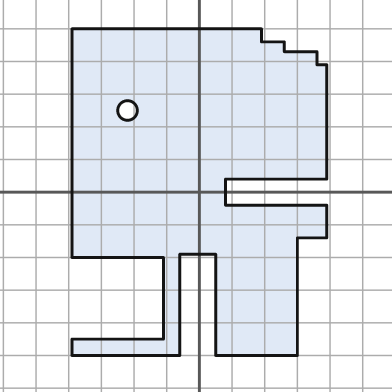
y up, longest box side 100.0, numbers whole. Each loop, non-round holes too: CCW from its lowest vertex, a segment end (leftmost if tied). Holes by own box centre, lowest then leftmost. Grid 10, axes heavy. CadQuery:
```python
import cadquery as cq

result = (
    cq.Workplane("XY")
    .moveTo(-39.0, -50.0)
    .lineTo(-6.0, -50.0)
    .lineTo(-6.0, -19.0)
    .lineTo(5.0, -19.0)
    .lineTo(5.0, -50.0)
    .lineTo(30.0, -50.0)
    .lineTo(30.0, -14.0)
    .lineTo(39.0, -14.0)
    .lineTo(39.0, -4.0)
    .lineTo(8.0, -4.0)
    .lineTo(8.0, 4.0)
    .lineTo(39.0, 4.0)
    .lineTo(39.0, 39.0)
    .lineTo(36.0, 39.0)
    .lineTo(36.0, 43.0)
    .lineTo(26.0, 43.0)
    .lineTo(26.0, 46.0)
    .lineTo(19.0, 46.0)
    .lineTo(19.0, 50.0)
    .lineTo(-39.0, 50.0)
    .lineTo(-39.0, -20.0)
    .lineTo(-11.0, -20.0)
    .lineTo(-11.0, -45.0)
    .lineTo(-39.0, -45.0)
    .close()
    .moveTo(-22.0, 25.0)
    .circle(3.0)
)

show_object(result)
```